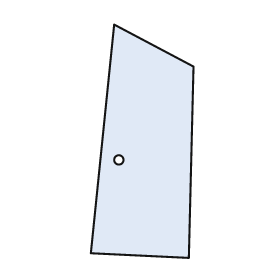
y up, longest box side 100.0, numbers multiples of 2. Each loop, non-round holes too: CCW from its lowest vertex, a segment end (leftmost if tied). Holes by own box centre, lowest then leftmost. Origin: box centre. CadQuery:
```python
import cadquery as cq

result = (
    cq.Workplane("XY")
    .moveTo(20.0, -50.0)
    .lineTo(22.0, 32.0)
    .lineTo(-12.0, 50.0)
    .lineTo(-22.0, -48.0)
    .close()
    .moveTo(-10.0, -8.0)
    .circle(2.0)
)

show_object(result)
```